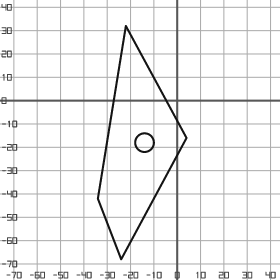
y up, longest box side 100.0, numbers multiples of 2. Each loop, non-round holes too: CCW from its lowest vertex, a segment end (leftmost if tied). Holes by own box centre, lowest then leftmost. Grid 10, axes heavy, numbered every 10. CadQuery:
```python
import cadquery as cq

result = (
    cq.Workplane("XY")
    .moveTo(-24.0, -68.0)
    .lineTo(4.0, -16.0)
    .lineTo(-22.0, 32.0)
    .lineTo(-34.0, -42.0)
    .close()
    .moveTo(-14.0, -18.0)
    .circle(4.0)
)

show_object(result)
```